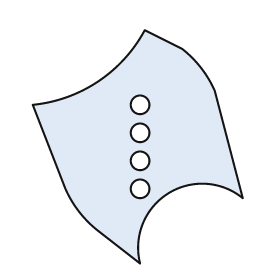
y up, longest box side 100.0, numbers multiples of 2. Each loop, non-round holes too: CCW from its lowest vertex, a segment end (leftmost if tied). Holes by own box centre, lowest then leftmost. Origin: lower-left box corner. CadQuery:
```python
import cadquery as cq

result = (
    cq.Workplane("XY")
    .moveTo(46.0, 0.0)
    .threePointArc((58.0, 30.0), (90.0, 28.0))
    .lineTo(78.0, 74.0)
    .threePointArc((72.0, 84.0), (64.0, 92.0))
    .lineTo(48.0, 100.0)
    .threePointArc((28.0, 78.0), (0.0, 68.0))
    .lineTo(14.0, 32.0)
    .threePointArc((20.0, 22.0), (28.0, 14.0))
    .close()
    .moveTo(46.0, 32.0)
    .circle(4.0)
    .moveTo(46.0, 44.0)
    .circle(4.0)
    .moveTo(46.0, 56.0)
    .circle(4.0)
    .moveTo(46.0, 68.0)
    .circle(4.0)
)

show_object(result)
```